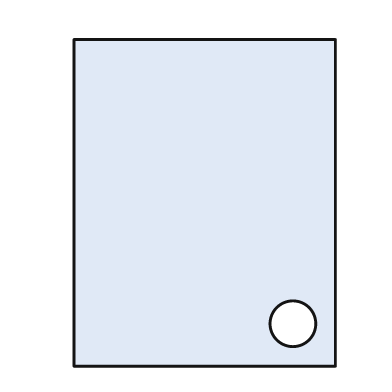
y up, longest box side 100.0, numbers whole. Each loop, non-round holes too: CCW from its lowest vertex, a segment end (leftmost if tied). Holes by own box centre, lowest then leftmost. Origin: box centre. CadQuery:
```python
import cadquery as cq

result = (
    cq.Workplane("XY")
    .moveTo(-40.0, -50.0)
    .lineTo(40.0, -50.0)
    .lineTo(40.0, 50.0)
    .lineTo(-40.0, 50.0)
    .close()
    .moveTo(27.0, -37.0)
    .circle(7.0)
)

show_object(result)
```